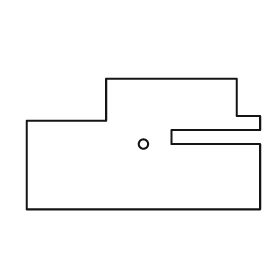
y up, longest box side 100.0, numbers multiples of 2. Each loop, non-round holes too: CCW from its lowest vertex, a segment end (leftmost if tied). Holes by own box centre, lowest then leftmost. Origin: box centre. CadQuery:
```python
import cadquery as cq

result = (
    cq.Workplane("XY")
    .moveTo(-50.0, -28.0)
    .lineTo(50.0, -28.0)
    .lineTo(50.0, 0.0)
    .lineTo(12.0, 0.0)
    .lineTo(12.0, 6.0)
    .lineTo(50.0, 6.0)
    .lineTo(50.0, 12.0)
    .lineTo(40.0, 12.0)
    .lineTo(40.0, 28.0)
    .lineTo(-16.0, 28.0)
    .lineTo(-16.0, 10.0)
    .lineTo(-50.0, 10.0)
    .close()
    .moveTo(0.0, 0.0)
    .circle(2.0)
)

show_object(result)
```